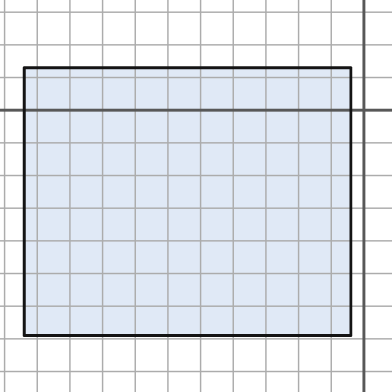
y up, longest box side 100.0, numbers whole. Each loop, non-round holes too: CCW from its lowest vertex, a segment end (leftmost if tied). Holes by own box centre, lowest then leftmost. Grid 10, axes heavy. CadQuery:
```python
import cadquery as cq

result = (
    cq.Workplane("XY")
    .moveTo(-104.0, -69.0)
    .lineTo(-4.0, -69.0)
    .lineTo(-4.0, 13.0)
    .lineTo(-104.0, 13.0)
    .close()
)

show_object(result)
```